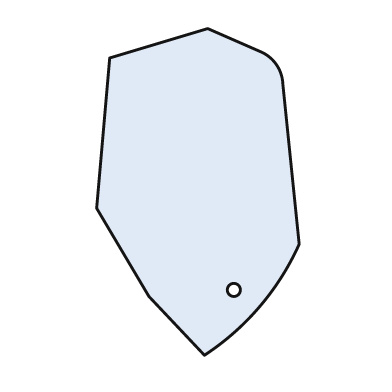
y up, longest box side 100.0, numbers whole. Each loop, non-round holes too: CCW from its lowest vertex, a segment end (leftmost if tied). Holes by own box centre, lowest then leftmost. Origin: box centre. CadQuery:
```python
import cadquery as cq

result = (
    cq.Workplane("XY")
    .moveTo(2.0, -50.0)
    .threePointArc((19.0, -35.0), (31.0, -16.0))
    .lineTo(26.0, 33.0)
    .threePointArc((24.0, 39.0), (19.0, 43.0))
    .lineTo(3.0, 50.0)
    .lineTo(-27.0, 41.0)
    .lineTo(-31.0, -5.0)
    .lineTo(-15.0, -32.0)
    .close()
    .moveTo(11.0, -30.0)
    .circle(2.0)
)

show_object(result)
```